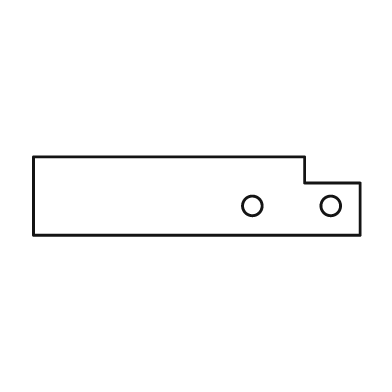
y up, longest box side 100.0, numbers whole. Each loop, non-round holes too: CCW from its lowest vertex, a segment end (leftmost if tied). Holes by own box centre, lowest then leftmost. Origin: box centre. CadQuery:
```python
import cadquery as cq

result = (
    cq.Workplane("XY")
    .moveTo(-50.0, -12.0)
    .lineTo(50.0, -12.0)
    .lineTo(50.0, 4.0)
    .lineTo(33.0, 4.0)
    .lineTo(33.0, 12.0)
    .lineTo(-50.0, 12.0)
    .close()
    .moveTo(17.0, -3.0)
    .circle(3.0)
    .moveTo(41.0, -3.0)
    .circle(3.0)
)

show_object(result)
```